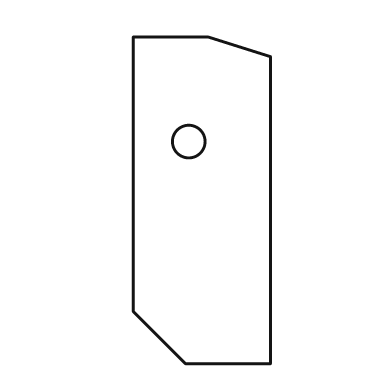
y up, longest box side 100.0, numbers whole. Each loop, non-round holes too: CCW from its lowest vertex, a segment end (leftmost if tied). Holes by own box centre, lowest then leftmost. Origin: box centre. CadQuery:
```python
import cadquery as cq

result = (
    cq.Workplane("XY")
    .moveTo(-5.0, -50.0)
    .lineTo(21.0, -50.0)
    .lineTo(21.0, 44.0)
    .lineTo(2.0, 50.0)
    .lineTo(-21.0, 50.0)
    .lineTo(-21.0, -34.0)
    .close()
    .moveTo(-4.0, 18.0)
    .circle(5.0)
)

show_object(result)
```